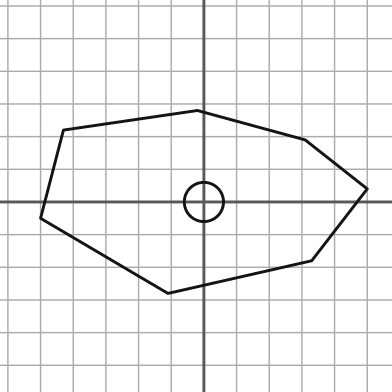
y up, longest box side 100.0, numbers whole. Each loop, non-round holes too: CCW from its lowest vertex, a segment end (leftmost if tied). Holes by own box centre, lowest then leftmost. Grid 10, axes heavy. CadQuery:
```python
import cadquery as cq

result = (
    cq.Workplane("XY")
    .moveTo(-11.0, -28.0)
    .lineTo(33.0, -18.0)
    .lineTo(50.0, 4.0)
    .lineTo(31.0, 19.0)
    .lineTo(-2.0, 28.0)
    .lineTo(-43.0, 22.0)
    .lineTo(-50.0, -5.0)
    .close()
    .moveTo(0.0, 0.0)
    .circle(6.0)
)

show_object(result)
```